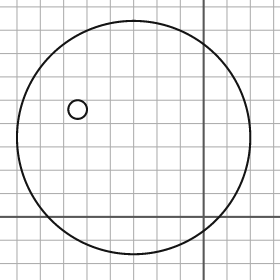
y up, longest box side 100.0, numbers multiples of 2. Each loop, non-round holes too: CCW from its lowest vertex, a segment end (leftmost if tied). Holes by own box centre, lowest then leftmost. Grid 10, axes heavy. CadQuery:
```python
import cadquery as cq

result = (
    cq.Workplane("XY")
    .moveTo(-30.0, 34.0)
    .circle(50.0)
    .moveTo(-54.0, 46.0)
    .circle(4.0)
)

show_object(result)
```